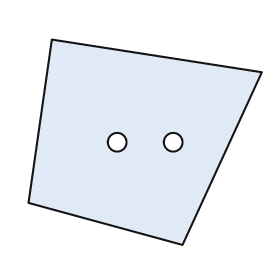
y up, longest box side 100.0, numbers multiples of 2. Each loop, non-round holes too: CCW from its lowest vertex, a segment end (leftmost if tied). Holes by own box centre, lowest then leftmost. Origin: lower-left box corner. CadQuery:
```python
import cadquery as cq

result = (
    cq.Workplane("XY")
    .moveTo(66.0, 0.0)
    .lineTo(100.0, 74.0)
    .lineTo(10.0, 88.0)
    .lineTo(0.0, 18.0)
    .close()
    .moveTo(38.0, 44.0)
    .circle(4.0)
    .moveTo(62.0, 44.0)
    .circle(4.0)
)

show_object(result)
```